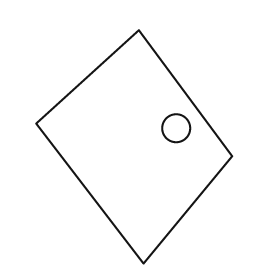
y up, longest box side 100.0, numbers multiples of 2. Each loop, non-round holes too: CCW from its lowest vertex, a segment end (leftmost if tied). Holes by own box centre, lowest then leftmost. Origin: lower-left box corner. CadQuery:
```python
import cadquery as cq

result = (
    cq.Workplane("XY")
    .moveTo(46.0, 0.0)
    .lineTo(84.0, 46.0)
    .lineTo(44.0, 100.0)
    .lineTo(0.0, 60.0)
    .close()
    .moveTo(60.0, 58.0)
    .circle(6.0)
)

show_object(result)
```